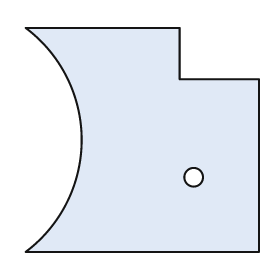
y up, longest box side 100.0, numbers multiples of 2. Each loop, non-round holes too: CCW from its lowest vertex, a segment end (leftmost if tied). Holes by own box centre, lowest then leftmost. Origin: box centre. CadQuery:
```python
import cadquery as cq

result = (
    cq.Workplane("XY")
    .moveTo(-50.0, -48.0)
    .lineTo(50.0, -48.0)
    .lineTo(50.0, 26.0)
    .lineTo(16.0, 26.0)
    .lineTo(16.0, 48.0)
    .lineTo(-50.0, 48.0)
    .threePointArc((-26.0, 0.0), (-50.0, -48.0))
    .close()
    .moveTo(22.0, -16.0)
    .circle(4.0)
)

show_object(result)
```